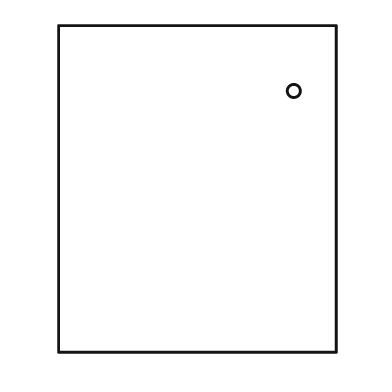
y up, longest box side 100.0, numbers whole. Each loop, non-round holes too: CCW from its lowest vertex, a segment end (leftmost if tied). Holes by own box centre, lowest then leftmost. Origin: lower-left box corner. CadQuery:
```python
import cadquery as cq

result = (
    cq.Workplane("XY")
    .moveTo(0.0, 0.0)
    .lineTo(85.0, 0.0)
    .lineTo(85.0, 100.0)
    .lineTo(0.0, 100.0)
    .close()
    .moveTo(72.0, 80.0)
    .circle(2.0)
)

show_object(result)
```